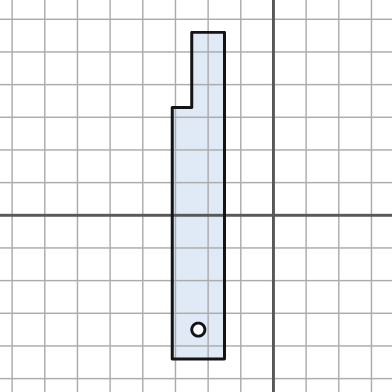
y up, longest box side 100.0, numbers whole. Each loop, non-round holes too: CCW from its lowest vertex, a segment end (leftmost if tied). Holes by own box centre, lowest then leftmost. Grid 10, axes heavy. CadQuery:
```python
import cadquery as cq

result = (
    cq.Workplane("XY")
    .moveTo(-31.0, -44.0)
    .lineTo(-15.0, -44.0)
    .lineTo(-15.0, 56.0)
    .lineTo(-25.0, 56.0)
    .lineTo(-25.0, 33.0)
    .lineTo(-31.0, 33.0)
    .close()
    .moveTo(-23.0, -35.0)
    .circle(2.0)
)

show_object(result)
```